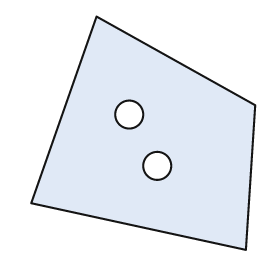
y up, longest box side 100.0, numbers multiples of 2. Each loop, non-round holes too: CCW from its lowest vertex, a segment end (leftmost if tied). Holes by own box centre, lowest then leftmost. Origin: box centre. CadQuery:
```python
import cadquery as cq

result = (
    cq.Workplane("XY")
    .moveTo(44.0, -50.0)
    .lineTo(48.0, 12.0)
    .lineTo(-20.0, 50.0)
    .lineTo(-48.0, -30.0)
    .close()
    .moveTo(6.0, -14.0)
    .circle(6.0)
    .moveTo(-6.0, 8.0)
    .circle(6.0)
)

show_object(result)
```